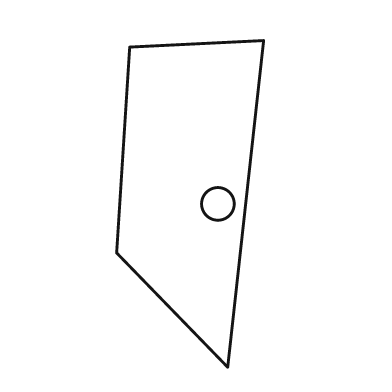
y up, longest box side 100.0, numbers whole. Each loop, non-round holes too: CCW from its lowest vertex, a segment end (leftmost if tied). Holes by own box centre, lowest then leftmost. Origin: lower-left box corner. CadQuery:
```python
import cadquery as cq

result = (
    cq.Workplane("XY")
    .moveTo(34.0, 0.0)
    .lineTo(45.0, 100.0)
    .lineTo(4.0, 98.0)
    .lineTo(0.0, 35.0)
    .close()
    .moveTo(31.0, 50.0)
    .circle(5.0)
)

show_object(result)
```